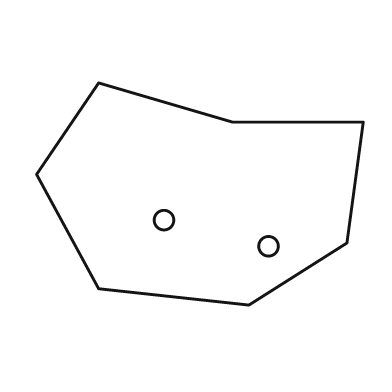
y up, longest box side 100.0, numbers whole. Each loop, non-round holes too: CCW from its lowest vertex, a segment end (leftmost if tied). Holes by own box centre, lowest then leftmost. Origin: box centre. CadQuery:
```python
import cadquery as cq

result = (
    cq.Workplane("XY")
    .moveTo(15.0, -34.0)
    .lineTo(45.0, -15.0)
    .lineTo(50.0, 22.0)
    .lineTo(10.0, 22.0)
    .lineTo(-31.0, 34.0)
    .lineTo(-50.0, 6.0)
    .lineTo(-31.0, -29.0)
    .close()
    .moveTo(21.0, -16.0)
    .circle(3.0)
    .moveTo(-11.0, -8.0)
    .circle(3.0)
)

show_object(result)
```